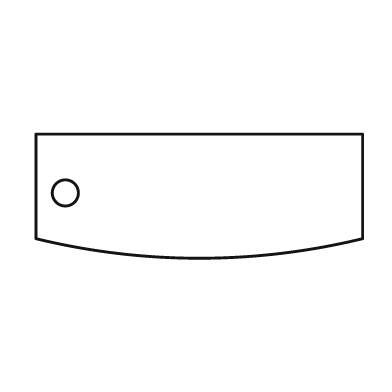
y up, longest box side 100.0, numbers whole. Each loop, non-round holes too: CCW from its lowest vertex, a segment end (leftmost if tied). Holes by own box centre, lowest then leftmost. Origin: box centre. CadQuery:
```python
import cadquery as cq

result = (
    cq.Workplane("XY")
    .moveTo(-50.0, -13.0)
    .threePointArc((0.0, -19.0), (50.0, -13.0))
    .lineTo(50.0, 19.0)
    .lineTo(-50.0, 19.0)
    .close()
    .moveTo(-41.0, 1.0)
    .circle(4.0)
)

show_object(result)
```